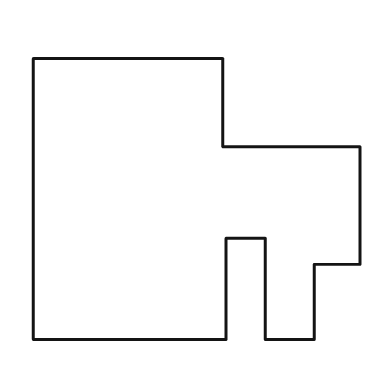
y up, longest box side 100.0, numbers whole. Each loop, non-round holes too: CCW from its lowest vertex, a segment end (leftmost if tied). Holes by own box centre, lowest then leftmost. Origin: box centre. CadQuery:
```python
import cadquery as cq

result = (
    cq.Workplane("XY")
    .moveTo(-50.0, -43.0)
    .lineTo(9.0, -43.0)
    .lineTo(9.0, -12.0)
    .lineTo(21.0, -12.0)
    .lineTo(21.0, -43.0)
    .lineTo(36.0, -43.0)
    .lineTo(36.0, -20.0)
    .lineTo(50.0, -20.0)
    .lineTo(50.0, 16.0)
    .lineTo(8.0, 16.0)
    .lineTo(8.0, 43.0)
    .lineTo(-50.0, 43.0)
    .close()
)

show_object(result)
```